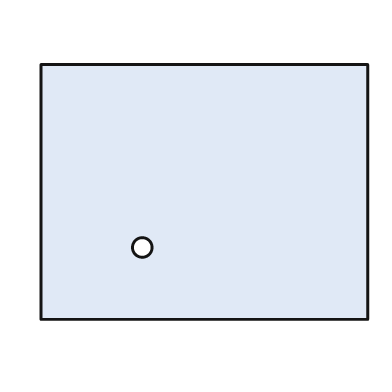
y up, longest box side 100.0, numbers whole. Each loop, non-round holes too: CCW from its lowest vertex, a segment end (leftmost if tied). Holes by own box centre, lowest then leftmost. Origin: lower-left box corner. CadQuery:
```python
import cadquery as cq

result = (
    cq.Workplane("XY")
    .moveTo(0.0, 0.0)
    .lineTo(100.0, 0.0)
    .lineTo(100.0, 78.0)
    .lineTo(0.0, 78.0)
    .close()
    .moveTo(31.0, 22.0)
    .circle(3.0)
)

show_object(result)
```